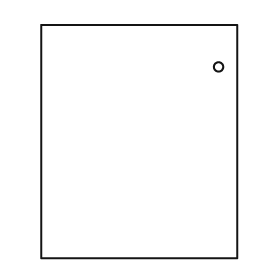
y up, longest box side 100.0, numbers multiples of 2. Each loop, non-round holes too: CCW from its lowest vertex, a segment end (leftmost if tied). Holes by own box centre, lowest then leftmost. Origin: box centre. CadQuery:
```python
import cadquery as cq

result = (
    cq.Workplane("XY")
    .moveTo(-42.0, -50.0)
    .lineTo(42.0, -50.0)
    .lineTo(42.0, 50.0)
    .lineTo(-42.0, 50.0)
    .close()
    .moveTo(34.0, 32.0)
    .circle(2.0)
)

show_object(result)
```